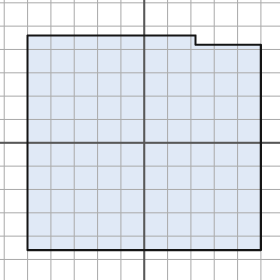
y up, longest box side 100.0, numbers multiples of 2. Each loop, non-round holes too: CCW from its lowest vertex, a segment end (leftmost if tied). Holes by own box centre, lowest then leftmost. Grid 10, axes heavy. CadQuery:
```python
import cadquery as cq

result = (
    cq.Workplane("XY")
    .moveTo(-50.0, -46.0)
    .lineTo(50.0, -46.0)
    .lineTo(50.0, 42.0)
    .lineTo(22.0, 42.0)
    .lineTo(22.0, 46.0)
    .lineTo(-50.0, 46.0)
    .close()
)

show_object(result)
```